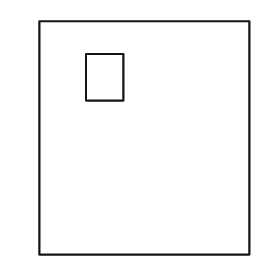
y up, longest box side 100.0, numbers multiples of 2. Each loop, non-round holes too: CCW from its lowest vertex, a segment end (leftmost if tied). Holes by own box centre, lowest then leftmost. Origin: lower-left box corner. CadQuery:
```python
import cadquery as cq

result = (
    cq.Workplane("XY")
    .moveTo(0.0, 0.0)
    .lineTo(90.0, 0.0)
    .lineTo(90.0, 100.0)
    .lineTo(0.0, 100.0)
    .close()
    .moveTo(20.0, 66.0)
    .lineTo(36.0, 66.0)
    .lineTo(36.0, 86.0)
    .lineTo(20.0, 86.0)
    .close()
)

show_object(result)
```